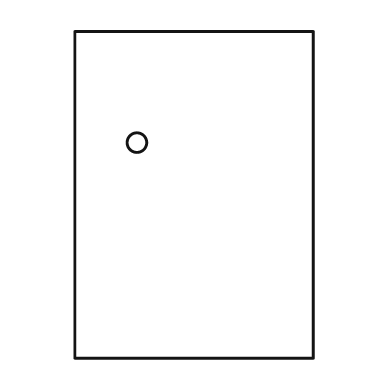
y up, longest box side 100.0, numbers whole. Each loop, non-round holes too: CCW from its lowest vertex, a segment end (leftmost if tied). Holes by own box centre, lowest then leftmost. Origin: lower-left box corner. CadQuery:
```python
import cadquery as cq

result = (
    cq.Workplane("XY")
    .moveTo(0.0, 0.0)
    .lineTo(73.0, 0.0)
    .lineTo(73.0, 100.0)
    .lineTo(0.0, 100.0)
    .close()
    .moveTo(19.0, 66.0)
    .circle(3.0)
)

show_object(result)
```